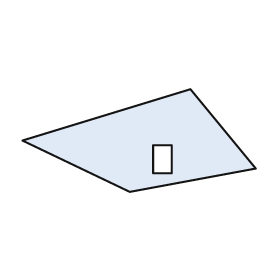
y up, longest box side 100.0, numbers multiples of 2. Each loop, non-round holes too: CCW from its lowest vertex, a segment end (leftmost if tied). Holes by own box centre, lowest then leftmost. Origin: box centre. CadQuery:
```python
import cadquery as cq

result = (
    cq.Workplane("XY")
    .moveTo(-4.0, -22.0)
    .lineTo(50.0, -12.0)
    .lineTo(22.0, 22.0)
    .lineTo(-50.0, 0.0)
    .close()
    .moveTo(6.0, -14.0)
    .lineTo(14.0, -14.0)
    .lineTo(14.0, -2.0)
    .lineTo(6.0, -2.0)
    .close()
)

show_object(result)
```